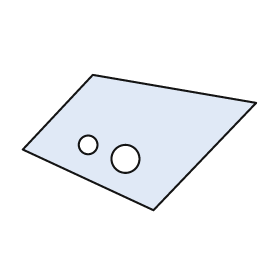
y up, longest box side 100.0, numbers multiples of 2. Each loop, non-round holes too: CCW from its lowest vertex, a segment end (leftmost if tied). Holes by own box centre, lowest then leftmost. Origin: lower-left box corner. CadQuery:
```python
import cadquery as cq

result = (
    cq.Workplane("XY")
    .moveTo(56.0, 0.0)
    .lineTo(100.0, 46.0)
    .lineTo(30.0, 58.0)
    .lineTo(0.0, 26.0)
    .close()
    .moveTo(44.0, 22.0)
    .circle(6.0)
    .moveTo(28.0, 28.0)
    .circle(4.0)
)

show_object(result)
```